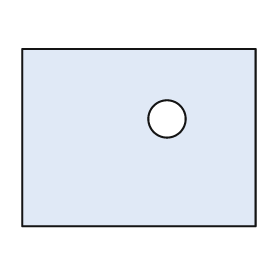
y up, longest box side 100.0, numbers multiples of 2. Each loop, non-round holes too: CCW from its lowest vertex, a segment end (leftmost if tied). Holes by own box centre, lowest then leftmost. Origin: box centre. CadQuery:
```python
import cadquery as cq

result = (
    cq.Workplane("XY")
    .moveTo(-50.0, -38.0)
    .lineTo(50.0, -38.0)
    .lineTo(50.0, 38.0)
    .lineTo(-50.0, 38.0)
    .close()
    .moveTo(12.0, 8.0)
    .circle(8.0)
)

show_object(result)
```